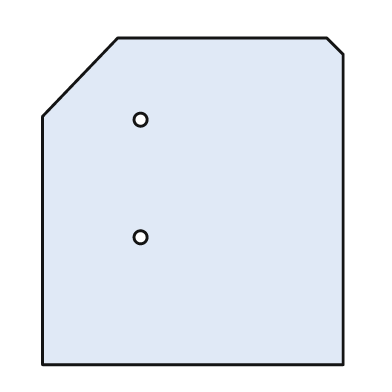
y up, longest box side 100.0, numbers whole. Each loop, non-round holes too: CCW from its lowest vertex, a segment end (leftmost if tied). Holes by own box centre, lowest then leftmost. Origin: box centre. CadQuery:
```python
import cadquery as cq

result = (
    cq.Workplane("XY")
    .moveTo(-46.0, -50.0)
    .lineTo(46.0, -50.0)
    .lineTo(46.0, 45.0)
    .lineTo(41.0, 50.0)
    .lineTo(-23.0, 50.0)
    .lineTo(-46.0, 26.0)
    .close()
    .moveTo(-16.0, -11.0)
    .circle(2.0)
    .moveTo(-16.0, 25.0)
    .circle(2.0)
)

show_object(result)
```